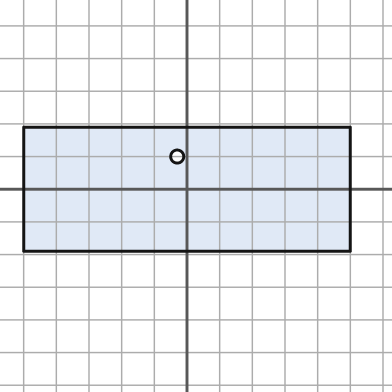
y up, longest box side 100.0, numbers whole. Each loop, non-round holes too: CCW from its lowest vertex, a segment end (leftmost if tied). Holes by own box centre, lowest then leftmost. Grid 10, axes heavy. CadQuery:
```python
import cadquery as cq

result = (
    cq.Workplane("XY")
    .moveTo(-50.0, -19.0)
    .lineTo(50.0, -19.0)
    .lineTo(50.0, 19.0)
    .lineTo(-50.0, 19.0)
    .close()
    .moveTo(-3.0, 10.0)
    .circle(2.0)
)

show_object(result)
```